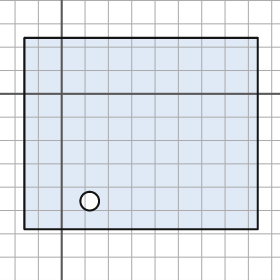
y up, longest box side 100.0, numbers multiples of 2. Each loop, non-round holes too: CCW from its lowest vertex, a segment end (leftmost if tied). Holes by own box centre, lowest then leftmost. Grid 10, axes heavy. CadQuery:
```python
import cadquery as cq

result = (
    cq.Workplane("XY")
    .moveTo(-16.0, -58.0)
    .lineTo(84.0, -58.0)
    .lineTo(84.0, 24.0)
    .lineTo(-16.0, 24.0)
    .close()
    .moveTo(12.0, -46.0)
    .circle(4.0)
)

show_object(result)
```